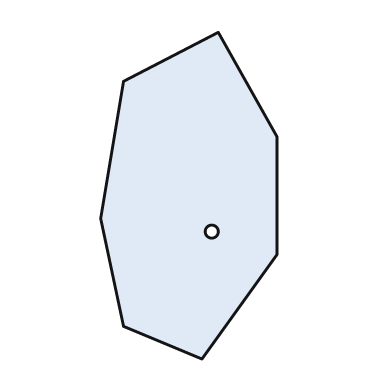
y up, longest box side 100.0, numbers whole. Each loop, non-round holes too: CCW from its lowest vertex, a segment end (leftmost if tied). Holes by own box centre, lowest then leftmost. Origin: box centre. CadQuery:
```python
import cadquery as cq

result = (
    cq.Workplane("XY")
    .moveTo(4.0, -50.0)
    .lineTo(27.0, -18.0)
    .lineTo(27.0, 18.0)
    .lineTo(9.0, 50.0)
    .lineTo(-20.0, 35.0)
    .lineTo(-27.0, -7.0)
    .lineTo(-20.0, -40.0)
    .close()
    .moveTo(7.0, -11.0)
    .circle(2.0)
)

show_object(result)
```